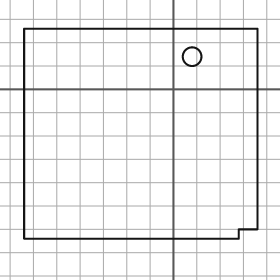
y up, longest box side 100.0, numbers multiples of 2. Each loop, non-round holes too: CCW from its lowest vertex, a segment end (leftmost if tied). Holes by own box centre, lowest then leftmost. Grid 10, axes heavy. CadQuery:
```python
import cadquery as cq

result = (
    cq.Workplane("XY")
    .moveTo(-64.0, -64.0)
    .lineTo(28.0, -64.0)
    .lineTo(28.0, -60.0)
    .lineTo(36.0, -60.0)
    .lineTo(36.0, 26.0)
    .lineTo(-64.0, 26.0)
    .close()
    .moveTo(8.0, 14.0)
    .circle(4.0)
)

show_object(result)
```